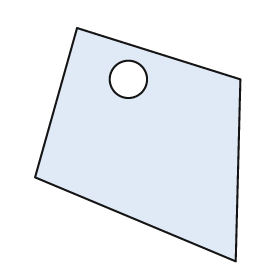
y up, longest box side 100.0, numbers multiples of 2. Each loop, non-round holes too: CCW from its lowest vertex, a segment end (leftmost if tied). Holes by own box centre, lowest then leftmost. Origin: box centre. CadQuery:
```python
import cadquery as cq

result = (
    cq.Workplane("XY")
    .moveTo(42.0, -50.0)
    .lineTo(44.0, 28.0)
    .lineTo(-26.0, 50.0)
    .lineTo(-44.0, -14.0)
    .close()
    .moveTo(-4.0, 28.0)
    .circle(8.0)
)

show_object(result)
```